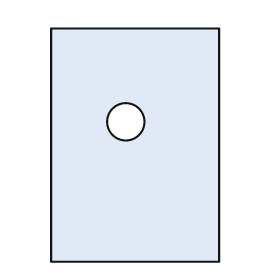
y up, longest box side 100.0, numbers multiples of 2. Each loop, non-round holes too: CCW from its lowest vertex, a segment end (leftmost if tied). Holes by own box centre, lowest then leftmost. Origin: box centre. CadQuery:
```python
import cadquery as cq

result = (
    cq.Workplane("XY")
    .moveTo(-36.0, -50.0)
    .lineTo(36.0, -50.0)
    .lineTo(36.0, 50.0)
    .lineTo(-36.0, 50.0)
    .close()
    .moveTo(-4.0, 10.0)
    .circle(8.0)
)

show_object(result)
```